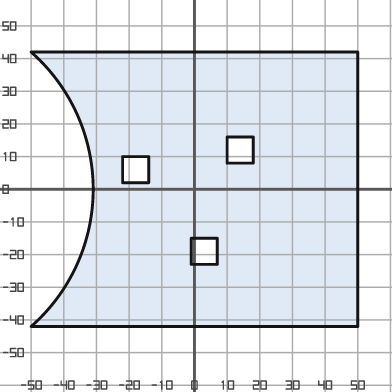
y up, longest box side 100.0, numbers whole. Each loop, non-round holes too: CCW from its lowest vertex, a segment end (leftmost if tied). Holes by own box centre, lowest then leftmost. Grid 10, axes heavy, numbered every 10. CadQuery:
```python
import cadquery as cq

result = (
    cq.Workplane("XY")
    .moveTo(-50.0, -42.0)
    .lineTo(50.0, -42.0)
    .lineTo(50.0, 42.0)
    .lineTo(-50.0, 42.0)
    .threePointArc((-31.0, 0.0), (-50.0, -42.0))
    .close()
    .moveTo(-1.0, -23.0)
    .lineTo(7.0, -23.0)
    .lineTo(7.0, -15.0)
    .lineTo(-1.0, -15.0)
    .close()
    .moveTo(-22.0, 2.0)
    .lineTo(-14.0, 2.0)
    .lineTo(-14.0, 10.0)
    .lineTo(-22.0, 10.0)
    .close()
    .moveTo(10.0, 8.0)
    .lineTo(18.0, 8.0)
    .lineTo(18.0, 16.0)
    .lineTo(10.0, 16.0)
    .close()
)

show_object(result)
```